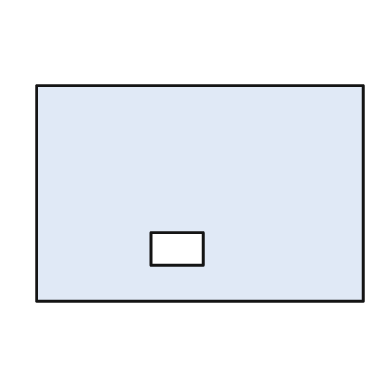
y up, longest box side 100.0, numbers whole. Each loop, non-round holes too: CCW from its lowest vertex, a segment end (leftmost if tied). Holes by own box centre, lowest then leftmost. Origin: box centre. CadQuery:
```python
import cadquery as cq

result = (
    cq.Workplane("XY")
    .moveTo(-50.0, -33.0)
    .lineTo(50.0, -33.0)
    .lineTo(50.0, 33.0)
    .lineTo(-50.0, 33.0)
    .close()
    .moveTo(-15.0, -22.0)
    .lineTo(1.0, -22.0)
    .lineTo(1.0, -12.0)
    .lineTo(-15.0, -12.0)
    .close()
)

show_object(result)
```